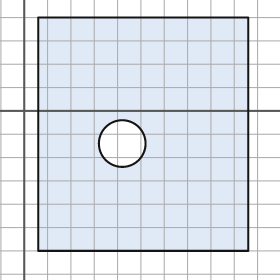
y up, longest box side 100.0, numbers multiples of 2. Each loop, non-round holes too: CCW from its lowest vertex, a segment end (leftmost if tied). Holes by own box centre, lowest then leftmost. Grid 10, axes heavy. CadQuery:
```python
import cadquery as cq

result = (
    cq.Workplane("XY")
    .moveTo(6.0, -60.0)
    .lineTo(96.0, -60.0)
    .lineTo(96.0, 40.0)
    .lineTo(6.0, 40.0)
    .close()
    .moveTo(42.0, -14.0)
    .circle(10.0)
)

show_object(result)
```